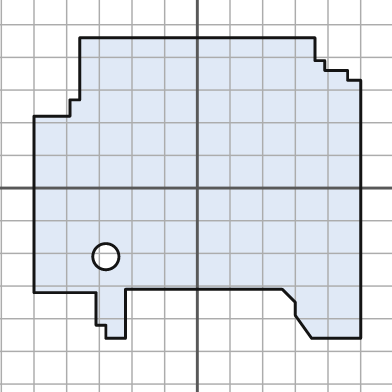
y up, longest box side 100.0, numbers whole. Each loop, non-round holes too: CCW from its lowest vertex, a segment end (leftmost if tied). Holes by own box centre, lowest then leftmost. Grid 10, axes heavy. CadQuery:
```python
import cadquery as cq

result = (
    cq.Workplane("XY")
    .moveTo(-28.0, -46.0)
    .lineTo(-22.0, -46.0)
    .lineTo(-22.0, -31.0)
    .lineTo(26.0, -31.0)
    .lineTo(30.0, -35.0)
    .lineTo(30.0, -39.0)
    .lineTo(35.0, -46.0)
    .lineTo(50.0, -46.0)
    .lineTo(50.0, 33.0)
    .lineTo(46.0, 33.0)
    .lineTo(46.0, 36.0)
    .lineTo(39.0, 36.0)
    .lineTo(39.0, 39.0)
    .lineTo(36.0, 39.0)
    .lineTo(36.0, 46.0)
    .lineTo(-36.0, 46.0)
    .lineTo(-36.0, 27.0)
    .lineTo(-39.0, 27.0)
    .lineTo(-39.0, 22.0)
    .lineTo(-50.0, 22.0)
    .lineTo(-50.0, -32.0)
    .lineTo(-31.0, -32.0)
    .lineTo(-31.0, -42.0)
    .lineTo(-28.0, -42.0)
    .close()
    .moveTo(-28.0, -21.0)
    .circle(4.0)
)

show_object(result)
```